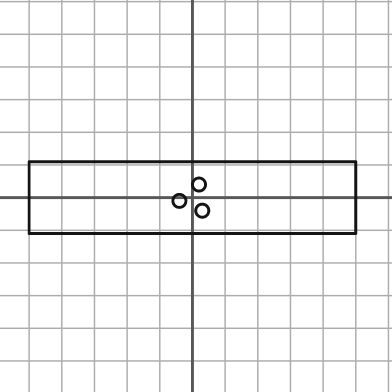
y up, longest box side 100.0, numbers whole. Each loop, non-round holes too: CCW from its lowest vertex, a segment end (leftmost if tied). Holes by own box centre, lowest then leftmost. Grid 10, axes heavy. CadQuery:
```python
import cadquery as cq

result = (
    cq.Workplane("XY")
    .moveTo(-50.0, -11.0)
    .lineTo(50.0, -11.0)
    .lineTo(50.0, 11.0)
    .lineTo(-50.0, 11.0)
    .close()
    .moveTo(3.0, -4.0)
    .circle(2.0)
    .moveTo(-4.0, -1.0)
    .circle(2.0)
    .moveTo(2.0, 4.0)
    .circle(2.0)
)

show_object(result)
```